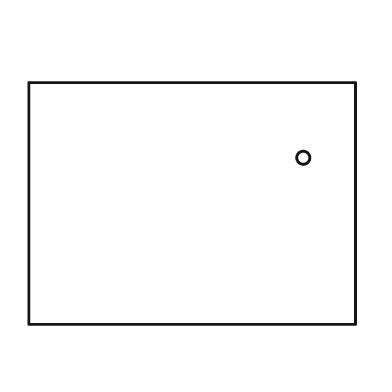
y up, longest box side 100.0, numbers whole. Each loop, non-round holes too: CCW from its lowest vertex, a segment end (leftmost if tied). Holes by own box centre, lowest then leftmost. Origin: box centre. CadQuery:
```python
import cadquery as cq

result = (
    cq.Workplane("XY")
    .moveTo(-50.0, -37.0)
    .lineTo(50.0, -37.0)
    .lineTo(50.0, 37.0)
    .lineTo(-50.0, 37.0)
    .close()
    .moveTo(34.0, 14.0)
    .circle(2.0)
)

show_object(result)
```